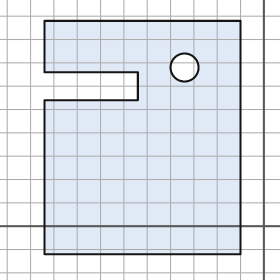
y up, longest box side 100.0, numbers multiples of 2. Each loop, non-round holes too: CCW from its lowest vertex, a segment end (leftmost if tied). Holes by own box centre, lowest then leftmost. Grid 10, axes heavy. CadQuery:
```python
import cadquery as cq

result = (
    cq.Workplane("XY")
    .moveTo(-94.0, -12.0)
    .lineTo(-10.0, -12.0)
    .lineTo(-10.0, 88.0)
    .lineTo(-94.0, 88.0)
    .lineTo(-94.0, 66.0)
    .lineTo(-54.0, 66.0)
    .lineTo(-54.0, 54.0)
    .lineTo(-94.0, 54.0)
    .close()
    .moveTo(-34.0, 68.0)
    .circle(6.0)
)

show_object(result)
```